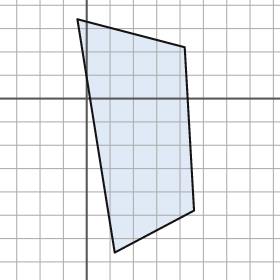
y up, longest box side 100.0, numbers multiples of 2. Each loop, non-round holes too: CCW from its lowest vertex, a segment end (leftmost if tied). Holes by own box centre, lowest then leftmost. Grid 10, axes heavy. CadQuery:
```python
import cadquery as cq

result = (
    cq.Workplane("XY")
    .moveTo(12.0, -66.0)
    .lineTo(46.0, -48.0)
    .lineTo(42.0, 22.0)
    .lineTo(-4.0, 34.0)
    .close()
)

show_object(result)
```